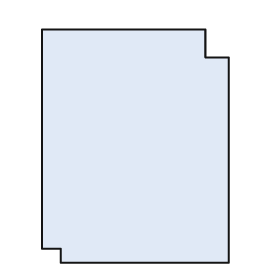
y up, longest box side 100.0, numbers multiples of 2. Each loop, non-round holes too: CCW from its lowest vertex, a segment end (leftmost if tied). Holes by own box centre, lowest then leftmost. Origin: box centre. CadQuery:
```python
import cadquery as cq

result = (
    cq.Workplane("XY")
    .moveTo(-32.0, -50.0)
    .lineTo(40.0, -50.0)
    .lineTo(40.0, 38.0)
    .lineTo(30.0, 38.0)
    .lineTo(30.0, 50.0)
    .lineTo(-40.0, 50.0)
    .lineTo(-40.0, -44.0)
    .lineTo(-32.0, -44.0)
    .close()
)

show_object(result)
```